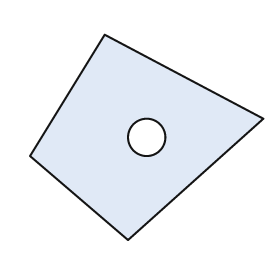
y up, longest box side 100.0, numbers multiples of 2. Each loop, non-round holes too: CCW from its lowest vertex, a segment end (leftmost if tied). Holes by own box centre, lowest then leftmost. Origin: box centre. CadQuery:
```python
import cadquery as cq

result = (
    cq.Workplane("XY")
    .moveTo(-8.0, -44.0)
    .lineTo(50.0, 8.0)
    .lineTo(-18.0, 44.0)
    .lineTo(-50.0, -8.0)
    .close()
    .moveTo(0.0, 0.0)
    .circle(8.0)
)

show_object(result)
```